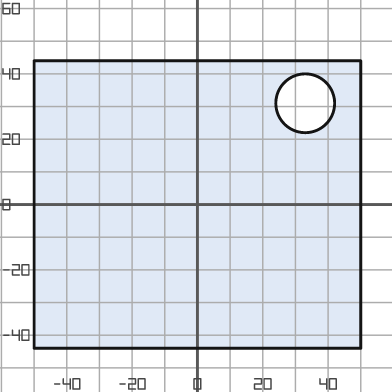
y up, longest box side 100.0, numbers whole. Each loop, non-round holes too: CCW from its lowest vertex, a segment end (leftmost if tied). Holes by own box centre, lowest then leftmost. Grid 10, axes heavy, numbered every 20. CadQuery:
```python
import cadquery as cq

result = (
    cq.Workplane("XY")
    .moveTo(-50.0, -44.0)
    .lineTo(50.0, -44.0)
    .lineTo(50.0, 44.0)
    .lineTo(-50.0, 44.0)
    .close()
    .moveTo(33.0, 31.0)
    .circle(9.0)
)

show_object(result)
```